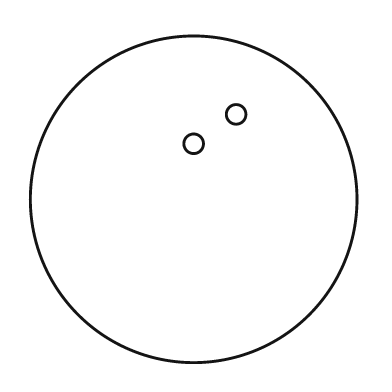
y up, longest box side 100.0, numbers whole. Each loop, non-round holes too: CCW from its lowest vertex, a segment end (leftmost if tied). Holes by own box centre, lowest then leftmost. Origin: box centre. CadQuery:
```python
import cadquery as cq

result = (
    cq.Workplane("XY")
    .moveTo(0.0, 0.0)
    .circle(50.0)
    .moveTo(0.0, 17.0)
    .circle(3.0)
    .moveTo(13.0, 26.0)
    .circle(3.0)
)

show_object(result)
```